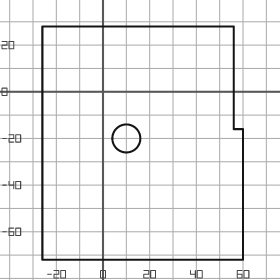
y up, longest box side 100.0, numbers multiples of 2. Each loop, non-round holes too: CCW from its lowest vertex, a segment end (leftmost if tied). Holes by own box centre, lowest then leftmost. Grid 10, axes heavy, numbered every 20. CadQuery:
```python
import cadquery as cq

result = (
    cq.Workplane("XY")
    .moveTo(-26.0, -72.0)
    .lineTo(60.0, -72.0)
    .lineTo(60.0, -16.0)
    .lineTo(56.0, -16.0)
    .lineTo(56.0, 28.0)
    .lineTo(-26.0, 28.0)
    .close()
    .moveTo(10.0, -20.0)
    .circle(6.0)
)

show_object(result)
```